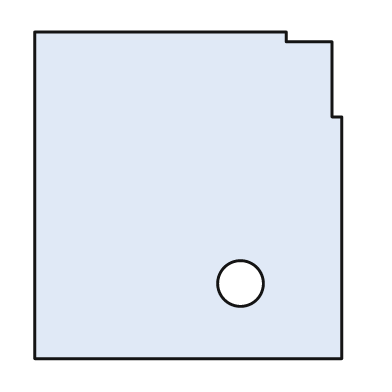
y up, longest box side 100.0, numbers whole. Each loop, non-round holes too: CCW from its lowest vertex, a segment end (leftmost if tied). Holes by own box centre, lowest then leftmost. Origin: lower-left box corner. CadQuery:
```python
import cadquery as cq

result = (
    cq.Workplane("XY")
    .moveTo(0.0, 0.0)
    .lineTo(94.0, 0.0)
    .lineTo(94.0, 74.0)
    .lineTo(91.0, 74.0)
    .lineTo(91.0, 97.0)
    .lineTo(77.0, 97.0)
    .lineTo(77.0, 100.0)
    .lineTo(0.0, 100.0)
    .close()
    .moveTo(63.0, 23.0)
    .circle(7.0)
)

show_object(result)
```